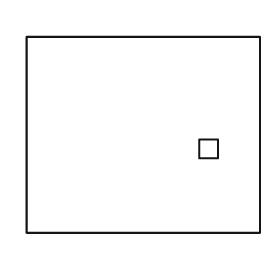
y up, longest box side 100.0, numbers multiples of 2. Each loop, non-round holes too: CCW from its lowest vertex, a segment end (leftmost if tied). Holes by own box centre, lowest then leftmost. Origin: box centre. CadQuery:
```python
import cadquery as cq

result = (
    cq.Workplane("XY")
    .moveTo(-50.0, -42.0)
    .lineTo(50.0, -42.0)
    .lineTo(50.0, 42.0)
    .lineTo(-50.0, 42.0)
    .close()
    .moveTo(24.0, -10.0)
    .lineTo(32.0, -10.0)
    .lineTo(32.0, -2.0)
    .lineTo(24.0, -2.0)
    .close()
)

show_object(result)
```